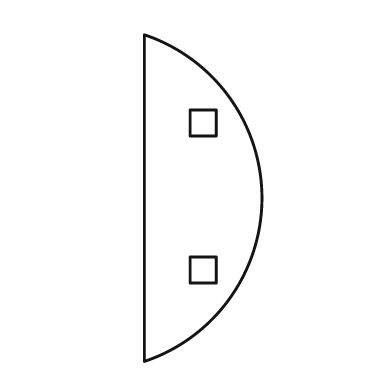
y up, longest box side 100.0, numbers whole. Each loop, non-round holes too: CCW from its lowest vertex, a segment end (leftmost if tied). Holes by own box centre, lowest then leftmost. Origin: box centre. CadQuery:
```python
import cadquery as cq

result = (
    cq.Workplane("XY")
    .moveTo(-18.0, -50.0)
    .threePointArc((18.0, 0.0), (-18.0, 50.0))
    .close()
    .moveTo(-4.0, -26.0)
    .lineTo(4.0, -26.0)
    .lineTo(4.0, -18.0)
    .lineTo(-4.0, -18.0)
    .close()
    .moveTo(-4.0, 19.0)
    .lineTo(4.0, 19.0)
    .lineTo(4.0, 27.0)
    .lineTo(-4.0, 27.0)
    .close()
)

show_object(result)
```